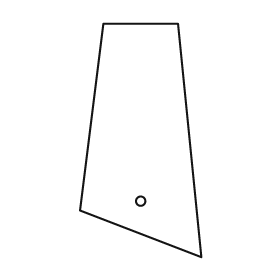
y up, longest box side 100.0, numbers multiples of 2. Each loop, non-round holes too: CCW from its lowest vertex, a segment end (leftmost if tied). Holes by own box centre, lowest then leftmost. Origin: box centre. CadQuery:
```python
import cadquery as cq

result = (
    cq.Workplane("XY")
    .moveTo(26.0, -50.0)
    .lineTo(16.0, 50.0)
    .lineTo(-16.0, 50.0)
    .lineTo(-26.0, -30.0)
    .close()
    .moveTo(0.0, -26.0)
    .circle(2.0)
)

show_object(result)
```